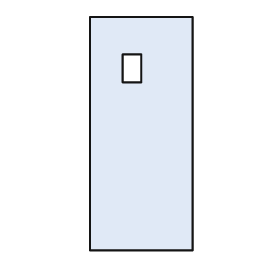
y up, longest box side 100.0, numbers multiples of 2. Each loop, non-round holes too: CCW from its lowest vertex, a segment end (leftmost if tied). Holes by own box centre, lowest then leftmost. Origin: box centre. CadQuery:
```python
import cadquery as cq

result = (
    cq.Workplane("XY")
    .moveTo(-22.0, -50.0)
    .lineTo(22.0, -50.0)
    .lineTo(22.0, 50.0)
    .lineTo(-22.0, 50.0)
    .close()
    .moveTo(-8.0, 22.0)
    .lineTo(0.0, 22.0)
    .lineTo(0.0, 34.0)
    .lineTo(-8.0, 34.0)
    .close()
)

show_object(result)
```